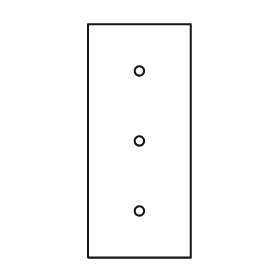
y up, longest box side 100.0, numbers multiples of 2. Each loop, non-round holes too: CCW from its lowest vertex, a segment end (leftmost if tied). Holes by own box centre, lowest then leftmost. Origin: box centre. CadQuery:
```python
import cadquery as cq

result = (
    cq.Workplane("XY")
    .moveTo(-22.0, -50.0)
    .lineTo(22.0, -50.0)
    .lineTo(22.0, 50.0)
    .lineTo(-22.0, 50.0)
    .close()
    .moveTo(0.0, -30.0)
    .circle(2.0)
    .moveTo(0.0, 0.0)
    .circle(2.0)
    .moveTo(0.0, 30.0)
    .circle(2.0)
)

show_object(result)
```